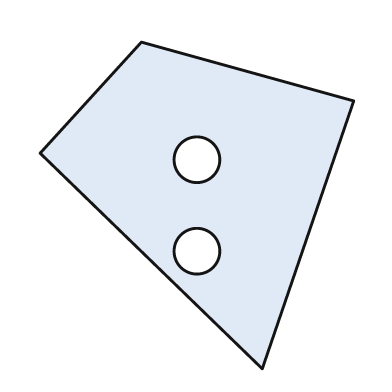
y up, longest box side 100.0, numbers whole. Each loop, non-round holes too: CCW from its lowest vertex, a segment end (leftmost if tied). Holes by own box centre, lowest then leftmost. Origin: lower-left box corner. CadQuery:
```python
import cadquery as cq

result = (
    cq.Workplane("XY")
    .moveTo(68.0, 0.0)
    .lineTo(96.0, 82.0)
    .lineTo(31.0, 100.0)
    .lineTo(0.0, 66.0)
    .close()
    .moveTo(48.0, 36.0)
    .circle(7.0)
    .moveTo(48.0, 64.0)
    .circle(7.0)
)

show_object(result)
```